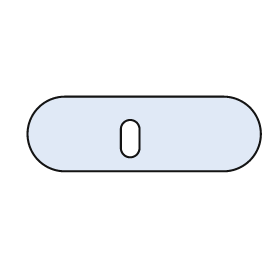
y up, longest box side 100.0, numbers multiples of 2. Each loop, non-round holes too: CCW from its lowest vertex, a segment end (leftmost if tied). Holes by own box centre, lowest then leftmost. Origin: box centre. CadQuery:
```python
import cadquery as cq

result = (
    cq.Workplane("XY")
    .moveTo(-34.0, -16.0)
    .lineTo(34.0, -16.0)
    .threePointArc((50.0, 0.0), (34.0, 16.0))
    .lineTo(-34.0, 16.0)
    .threePointArc((-50.0, 0.0), (-34.0, -16.0))
    .close()
    .moveTo(-10.0, -6.0)
    .threePointArc((-6.0, -10.0), (-2.0, -6.0))
    .lineTo(-2.0, 2.0)
    .threePointArc((-6.0, 6.0), (-10.0, 2.0))
    .close()
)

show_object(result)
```